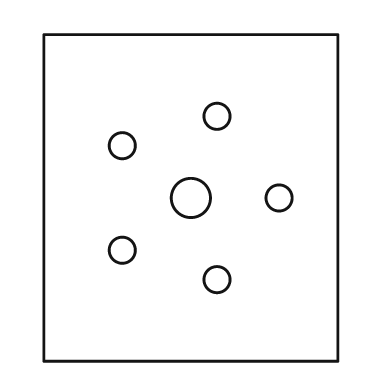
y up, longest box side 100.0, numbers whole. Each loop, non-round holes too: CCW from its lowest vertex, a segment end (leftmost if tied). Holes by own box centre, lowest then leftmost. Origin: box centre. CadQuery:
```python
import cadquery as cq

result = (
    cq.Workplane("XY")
    .moveTo(-45.0, -50.0)
    .lineTo(45.0, -50.0)
    .lineTo(45.0, 50.0)
    .lineTo(-45.0, 50.0)
    .close()
    .moveTo(8.0, -25.0)
    .circle(4.0)
    .moveTo(-21.0, -16.0)
    .circle(4.0)
    .moveTo(0.0, 0.0)
    .circle(6.0)
    .moveTo(27.0, 0.0)
    .circle(4.0)
    .moveTo(-21.0, 16.0)
    .circle(4.0)
    .moveTo(8.0, 25.0)
    .circle(4.0)
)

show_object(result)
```